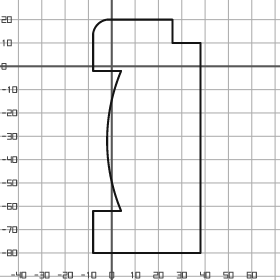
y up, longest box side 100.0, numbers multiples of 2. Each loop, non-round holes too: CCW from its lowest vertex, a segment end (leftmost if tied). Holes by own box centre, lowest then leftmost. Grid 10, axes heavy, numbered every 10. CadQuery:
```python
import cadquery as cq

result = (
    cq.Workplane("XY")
    .moveTo(-8.0, -80.0)
    .lineTo(38.0, -80.0)
    .lineTo(38.0, 10.0)
    .lineTo(26.0, 10.0)
    .lineTo(26.0, 20.0)
    .lineTo(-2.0, 20.0)
    .threePointArc((-6.0, 18.0), (-8.0, 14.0))
    .lineTo(-8.0, -2.0)
    .lineTo(4.0, -2.0)
    .threePointArc((-2.0, -32.0), (4.0, -62.0))
    .lineTo(-8.0, -62.0)
    .close()
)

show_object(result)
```